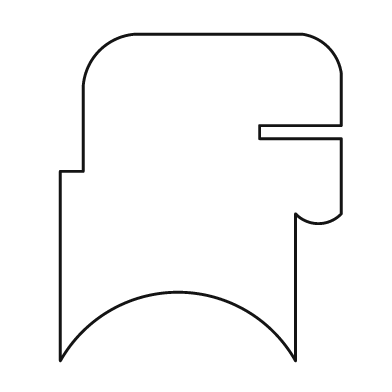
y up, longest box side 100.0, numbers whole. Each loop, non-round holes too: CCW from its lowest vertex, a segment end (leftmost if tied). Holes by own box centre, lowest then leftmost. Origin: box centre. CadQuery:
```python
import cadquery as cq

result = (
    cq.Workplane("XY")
    .moveTo(-43.0, -50.0)
    .threePointArc((-7.0, -29.0), (29.0, -50.0))
    .lineTo(29.0, -5.0)
    .threePointArc((36.0, -8.0), (43.0, -5.0))
    .lineTo(43.0, 18.0)
    .lineTo(18.0, 18.0)
    .lineTo(18.0, 22.0)
    .lineTo(43.0, 22.0)
    .lineTo(43.0, 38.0)
    .threePointArc((39.0, 46.0), (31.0, 50.0))
    .lineTo(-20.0, 50.0)
    .threePointArc((-31.0, 45.0), (-36.0, 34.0))
    .lineTo(-36.0, 8.0)
    .lineTo(-43.0, 8.0)
    .close()
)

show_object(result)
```